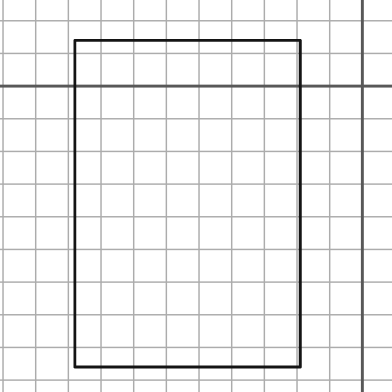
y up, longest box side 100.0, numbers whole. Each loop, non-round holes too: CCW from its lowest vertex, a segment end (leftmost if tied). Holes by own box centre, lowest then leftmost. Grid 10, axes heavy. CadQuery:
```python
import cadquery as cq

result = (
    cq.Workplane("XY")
    .moveTo(-88.0, -86.0)
    .lineTo(-19.0, -86.0)
    .lineTo(-19.0, 14.0)
    .lineTo(-88.0, 14.0)
    .close()
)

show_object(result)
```